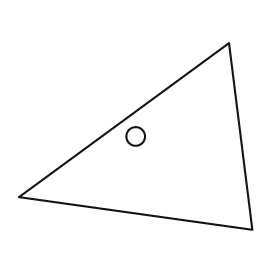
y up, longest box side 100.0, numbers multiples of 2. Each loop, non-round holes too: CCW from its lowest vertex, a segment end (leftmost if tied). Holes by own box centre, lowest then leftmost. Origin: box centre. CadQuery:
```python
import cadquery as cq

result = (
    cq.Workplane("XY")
    .moveTo(50.0, -40.0)
    .lineTo(40.0, 40.0)
    .lineTo(-50.0, -26.0)
    .close()
    .moveTo(0.0, 0.0)
    .circle(4.0)
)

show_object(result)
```